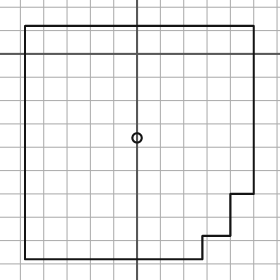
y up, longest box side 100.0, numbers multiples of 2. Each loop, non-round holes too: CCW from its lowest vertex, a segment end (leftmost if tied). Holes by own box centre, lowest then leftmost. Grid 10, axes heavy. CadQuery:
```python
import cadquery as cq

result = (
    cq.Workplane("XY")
    .moveTo(-48.0, -88.0)
    .lineTo(28.0, -88.0)
    .lineTo(28.0, -78.0)
    .lineTo(40.0, -78.0)
    .lineTo(40.0, -60.0)
    .lineTo(50.0, -60.0)
    .lineTo(50.0, 12.0)
    .lineTo(-48.0, 12.0)
    .close()
    .moveTo(0.0, -36.0)
    .circle(2.0)
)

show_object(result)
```